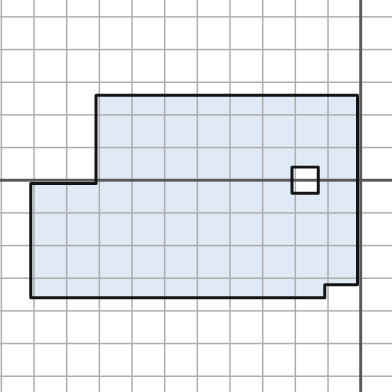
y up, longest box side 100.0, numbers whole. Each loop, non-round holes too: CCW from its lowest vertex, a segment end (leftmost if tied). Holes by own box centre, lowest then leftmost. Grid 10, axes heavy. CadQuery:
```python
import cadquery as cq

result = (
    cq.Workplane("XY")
    .moveTo(-101.0, -36.0)
    .lineTo(-11.0, -36.0)
    .lineTo(-11.0, -32.0)
    .lineTo(-1.0, -32.0)
    .lineTo(-1.0, 26.0)
    .lineTo(-81.0, 26.0)
    .lineTo(-81.0, -1.0)
    .lineTo(-101.0, -1.0)
    .close()
    .moveTo(-21.0, -4.0)
    .lineTo(-13.0, -4.0)
    .lineTo(-13.0, 4.0)
    .lineTo(-21.0, 4.0)
    .close()
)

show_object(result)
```